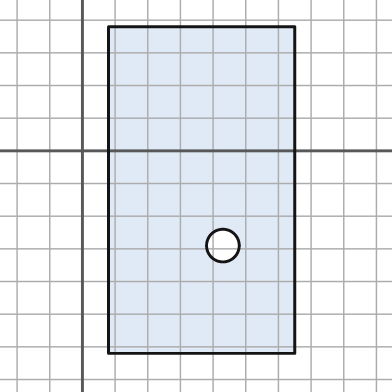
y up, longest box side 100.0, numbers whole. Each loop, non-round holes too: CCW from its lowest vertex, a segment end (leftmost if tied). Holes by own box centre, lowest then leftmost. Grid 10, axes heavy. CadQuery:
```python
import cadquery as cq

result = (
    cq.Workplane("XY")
    .moveTo(8.0, -62.0)
    .lineTo(65.0, -62.0)
    .lineTo(65.0, 38.0)
    .lineTo(8.0, 38.0)
    .close()
    .moveTo(43.0, -29.0)
    .circle(5.0)
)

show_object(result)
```